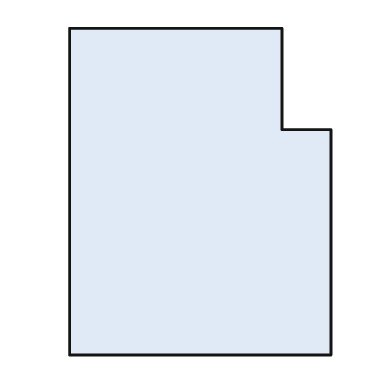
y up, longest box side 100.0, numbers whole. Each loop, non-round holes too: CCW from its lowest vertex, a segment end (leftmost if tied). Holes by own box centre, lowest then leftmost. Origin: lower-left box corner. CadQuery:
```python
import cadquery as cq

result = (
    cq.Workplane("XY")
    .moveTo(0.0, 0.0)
    .lineTo(80.0, 0.0)
    .lineTo(80.0, 69.0)
    .lineTo(65.0, 69.0)
    .lineTo(65.0, 100.0)
    .lineTo(0.0, 100.0)
    .close()
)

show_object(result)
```